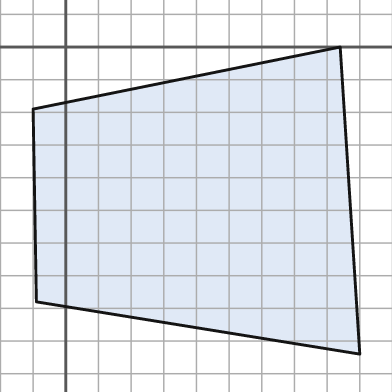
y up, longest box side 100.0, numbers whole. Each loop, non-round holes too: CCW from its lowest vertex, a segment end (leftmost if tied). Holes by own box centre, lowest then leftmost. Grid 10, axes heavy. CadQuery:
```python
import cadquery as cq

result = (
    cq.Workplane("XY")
    .moveTo(90.0, -94.0)
    .lineTo(84.0, 0.0)
    .lineTo(-10.0, -19.0)
    .lineTo(-9.0, -78.0)
    .close()
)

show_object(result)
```